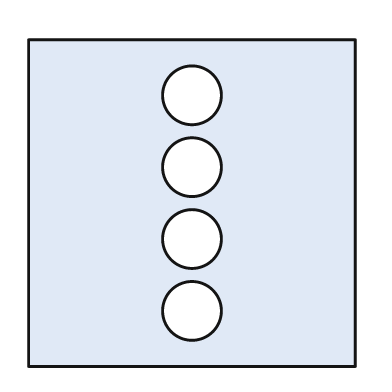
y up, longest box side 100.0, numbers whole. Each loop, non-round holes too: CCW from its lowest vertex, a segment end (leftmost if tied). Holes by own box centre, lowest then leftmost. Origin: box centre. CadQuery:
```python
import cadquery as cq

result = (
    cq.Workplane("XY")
    .moveTo(-50.0, -50.0)
    .lineTo(50.0, -50.0)
    .lineTo(50.0, 50.0)
    .lineTo(-50.0, 50.0)
    .close()
    .moveTo(0.0, -33.0)
    .circle(9.0)
    .moveTo(0.0, -11.0)
    .circle(9.0)
    .moveTo(0.0, 11.0)
    .circle(9.0)
    .moveTo(0.0, 33.0)
    .circle(9.0)
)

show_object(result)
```